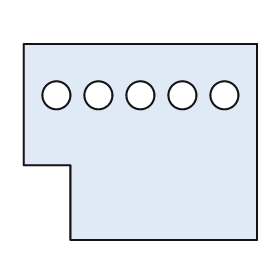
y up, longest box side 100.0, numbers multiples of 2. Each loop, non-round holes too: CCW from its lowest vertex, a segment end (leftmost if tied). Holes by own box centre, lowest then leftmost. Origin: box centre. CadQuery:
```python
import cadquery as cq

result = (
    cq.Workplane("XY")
    .moveTo(-30.0, -42.0)
    .lineTo(50.0, -42.0)
    .lineTo(50.0, 42.0)
    .lineTo(-50.0, 42.0)
    .lineTo(-50.0, -10.0)
    .lineTo(-30.0, -10.0)
    .close()
    .moveTo(-36.0, 20.0)
    .circle(6.0)
    .moveTo(-18.0, 20.0)
    .circle(6.0)
    .moveTo(0.0, 20.0)
    .circle(6.0)
    .moveTo(18.0, 20.0)
    .circle(6.0)
    .moveTo(36.0, 20.0)
    .circle(6.0)
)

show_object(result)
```